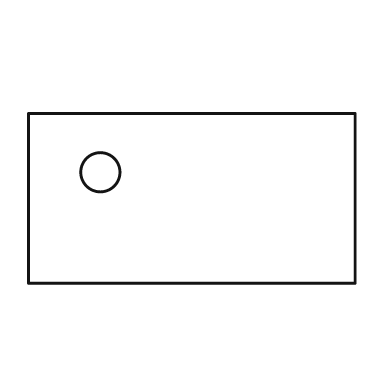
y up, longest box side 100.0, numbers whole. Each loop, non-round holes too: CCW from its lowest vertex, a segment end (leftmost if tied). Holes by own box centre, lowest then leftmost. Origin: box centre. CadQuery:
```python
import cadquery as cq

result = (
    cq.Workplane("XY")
    .moveTo(-50.0, -26.0)
    .lineTo(50.0, -26.0)
    .lineTo(50.0, 26.0)
    .lineTo(-50.0, 26.0)
    .close()
    .moveTo(-28.0, 8.0)
    .circle(6.0)
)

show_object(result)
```